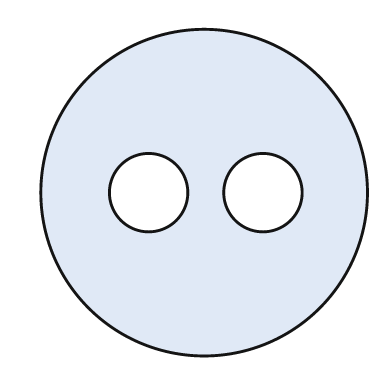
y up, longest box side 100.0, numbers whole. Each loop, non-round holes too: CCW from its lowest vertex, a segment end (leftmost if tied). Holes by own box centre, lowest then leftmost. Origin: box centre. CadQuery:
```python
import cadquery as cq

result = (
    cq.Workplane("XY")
    .moveTo(0.0, 0.0)
    .circle(50.0)
    .moveTo(-17.0, 0.0)
    .circle(12.0)
    .moveTo(18.0, 0.0)
    .circle(12.0)
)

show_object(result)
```